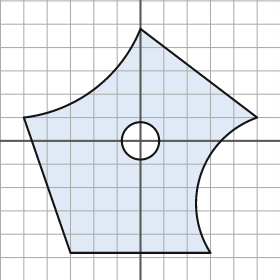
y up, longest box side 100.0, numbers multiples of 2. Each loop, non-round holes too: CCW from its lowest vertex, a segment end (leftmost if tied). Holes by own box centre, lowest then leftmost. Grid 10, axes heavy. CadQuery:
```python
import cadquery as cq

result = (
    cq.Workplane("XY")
    .moveTo(-30.0, -48.0)
    .lineTo(30.0, -48.0)
    .threePointArc((26.0, -14.0), (50.0, 10.0))
    .lineTo(0.0, 48.0)
    .threePointArc((-20.0, 22.0), (-50.0, 10.0))
    .close()
    .moveTo(0.0, 0.0)
    .circle(8.0)
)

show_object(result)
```